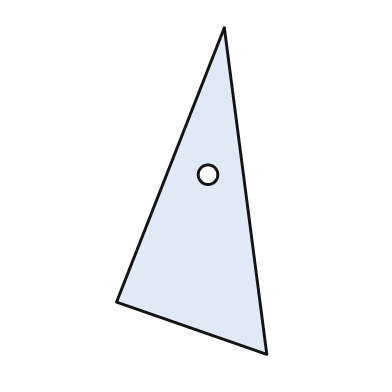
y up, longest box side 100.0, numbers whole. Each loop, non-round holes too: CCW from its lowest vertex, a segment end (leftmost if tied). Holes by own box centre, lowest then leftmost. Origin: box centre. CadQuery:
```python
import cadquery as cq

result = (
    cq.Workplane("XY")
    .moveTo(23.0, -50.0)
    .lineTo(10.0, 50.0)
    .lineTo(-23.0, -34.0)
    .close()
    .moveTo(5.0, 5.0)
    .circle(3.0)
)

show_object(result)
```